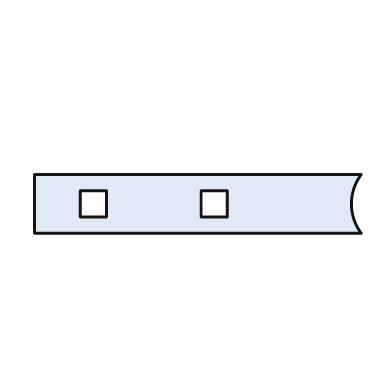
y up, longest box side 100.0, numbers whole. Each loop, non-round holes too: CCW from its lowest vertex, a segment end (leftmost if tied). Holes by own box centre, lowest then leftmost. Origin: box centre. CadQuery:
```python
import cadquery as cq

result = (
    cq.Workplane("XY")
    .moveTo(-50.0, -9.0)
    .lineTo(50.0, -9.0)
    .threePointArc((47.0, 0.0), (50.0, 9.0))
    .lineTo(-50.0, 9.0)
    .close()
    .moveTo(-36.0, -4.0)
    .lineTo(-28.0, -4.0)
    .lineTo(-28.0, 4.0)
    .lineTo(-36.0, 4.0)
    .close()
    .moveTo(1.0, -4.0)
    .lineTo(9.0, -4.0)
    .lineTo(9.0, 4.0)
    .lineTo(1.0, 4.0)
    .close()
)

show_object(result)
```